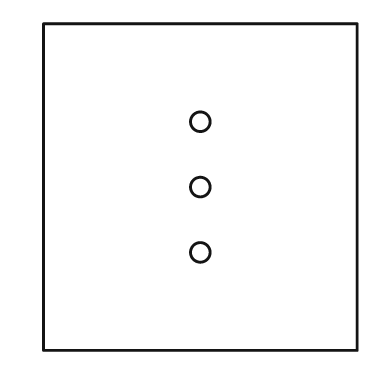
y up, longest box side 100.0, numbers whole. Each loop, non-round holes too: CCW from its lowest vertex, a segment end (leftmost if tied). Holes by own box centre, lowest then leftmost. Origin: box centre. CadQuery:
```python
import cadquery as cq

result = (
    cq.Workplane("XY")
    .moveTo(-48.0, -50.0)
    .lineTo(48.0, -50.0)
    .lineTo(48.0, 50.0)
    .lineTo(-48.0, 50.0)
    .close()
    .moveTo(0.0, -20.0)
    .circle(3.0)
    .moveTo(0.0, 0.0)
    .circle(3.0)
    .moveTo(0.0, 20.0)
    .circle(3.0)
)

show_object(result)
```